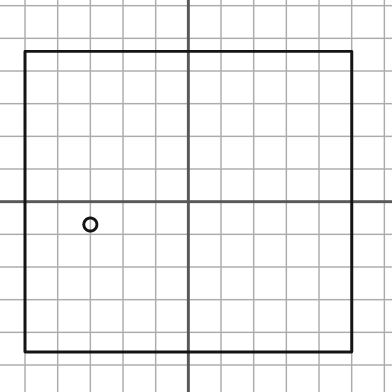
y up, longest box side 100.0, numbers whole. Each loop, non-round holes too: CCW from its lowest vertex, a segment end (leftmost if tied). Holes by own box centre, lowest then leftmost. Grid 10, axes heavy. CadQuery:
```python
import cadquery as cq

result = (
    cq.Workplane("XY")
    .moveTo(-50.0, -46.0)
    .lineTo(50.0, -46.0)
    .lineTo(50.0, 46.0)
    .lineTo(-50.0, 46.0)
    .close()
    .moveTo(-30.0, -7.0)
    .circle(2.0)
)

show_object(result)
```